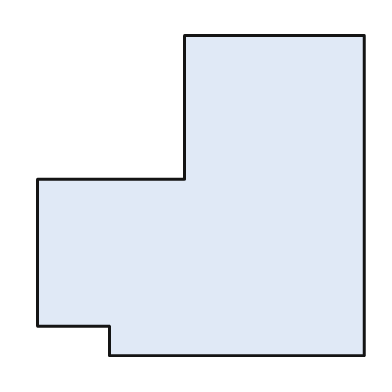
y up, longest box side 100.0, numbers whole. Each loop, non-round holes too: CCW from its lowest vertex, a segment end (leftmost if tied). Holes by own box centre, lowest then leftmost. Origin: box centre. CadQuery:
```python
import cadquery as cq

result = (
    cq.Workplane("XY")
    .moveTo(-28.0, -49.0)
    .lineTo(50.0, -49.0)
    .lineTo(50.0, 49.0)
    .lineTo(-5.0, 49.0)
    .lineTo(-5.0, 5.0)
    .lineTo(-50.0, 5.0)
    .lineTo(-50.0, -40.0)
    .lineTo(-28.0, -40.0)
    .close()
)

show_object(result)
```